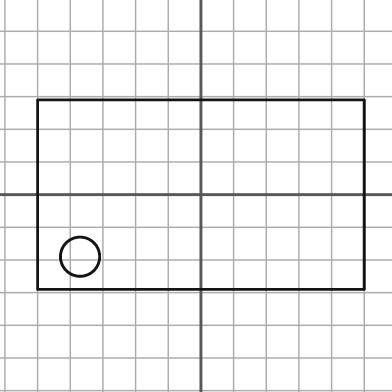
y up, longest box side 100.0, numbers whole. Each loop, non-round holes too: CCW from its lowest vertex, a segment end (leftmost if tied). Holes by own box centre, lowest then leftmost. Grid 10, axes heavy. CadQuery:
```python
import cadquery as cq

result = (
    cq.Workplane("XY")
    .moveTo(-50.0, -29.0)
    .lineTo(50.0, -29.0)
    .lineTo(50.0, 29.0)
    .lineTo(-50.0, 29.0)
    .close()
    .moveTo(-37.0, -19.0)
    .circle(6.0)
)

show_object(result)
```